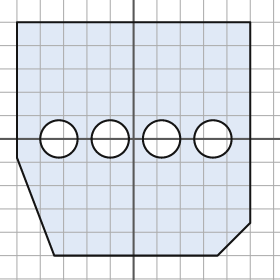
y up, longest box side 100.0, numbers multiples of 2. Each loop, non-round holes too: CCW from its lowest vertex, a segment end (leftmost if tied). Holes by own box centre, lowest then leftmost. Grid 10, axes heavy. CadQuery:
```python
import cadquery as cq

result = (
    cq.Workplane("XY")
    .moveTo(-34.0, -50.0)
    .lineTo(36.0, -50.0)
    .lineTo(50.0, -36.0)
    .lineTo(50.0, 50.0)
    .lineTo(-50.0, 50.0)
    .lineTo(-50.0, -8.0)
    .close()
    .moveTo(-32.0, 0.0)
    .circle(8.0)
    .moveTo(-10.0, 0.0)
    .circle(8.0)
    .moveTo(12.0, 0.0)
    .circle(8.0)
    .moveTo(34.0, 0.0)
    .circle(8.0)
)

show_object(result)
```